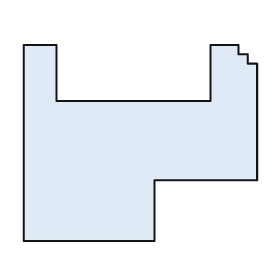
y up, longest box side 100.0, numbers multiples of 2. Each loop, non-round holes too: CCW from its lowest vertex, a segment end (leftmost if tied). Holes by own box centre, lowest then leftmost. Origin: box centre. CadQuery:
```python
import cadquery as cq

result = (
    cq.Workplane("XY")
    .moveTo(-50.0, -42.0)
    .lineTo(6.0, -42.0)
    .lineTo(6.0, -16.0)
    .lineTo(50.0, -16.0)
    .lineTo(50.0, 34.0)
    .lineTo(46.0, 34.0)
    .lineTo(46.0, 38.0)
    .lineTo(42.0, 38.0)
    .lineTo(42.0, 42.0)
    .lineTo(30.0, 42.0)
    .lineTo(30.0, 18.0)
    .lineTo(-36.0, 18.0)
    .lineTo(-36.0, 42.0)
    .lineTo(-50.0, 42.0)
    .close()
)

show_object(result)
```